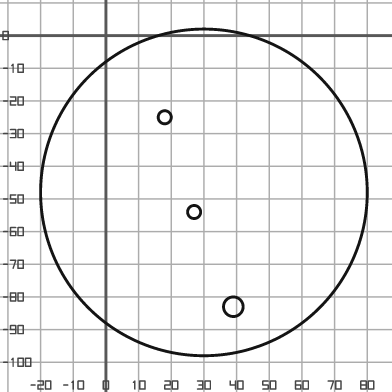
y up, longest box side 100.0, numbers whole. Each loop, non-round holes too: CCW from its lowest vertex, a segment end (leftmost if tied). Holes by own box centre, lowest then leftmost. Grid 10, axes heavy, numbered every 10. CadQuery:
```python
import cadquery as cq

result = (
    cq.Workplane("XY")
    .moveTo(30.0, -48.0)
    .circle(50.0)
    .moveTo(39.0, -83.0)
    .circle(3.0)
    .moveTo(27.0, -54.0)
    .circle(2.0)
    .moveTo(18.0, -25.0)
    .circle(2.0)
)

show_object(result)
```